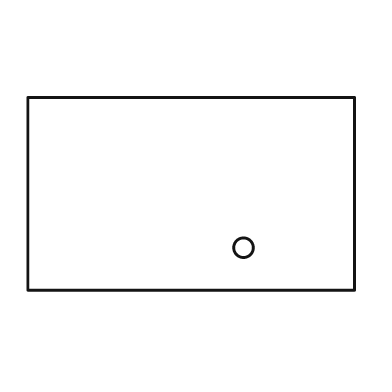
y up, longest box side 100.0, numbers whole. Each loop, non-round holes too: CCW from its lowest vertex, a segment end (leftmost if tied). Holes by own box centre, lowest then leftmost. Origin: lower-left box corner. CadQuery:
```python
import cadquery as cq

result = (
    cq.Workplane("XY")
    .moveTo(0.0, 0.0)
    .lineTo(100.0, 0.0)
    .lineTo(100.0, 59.0)
    .lineTo(0.0, 59.0)
    .close()
    .moveTo(66.0, 13.0)
    .circle(3.0)
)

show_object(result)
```